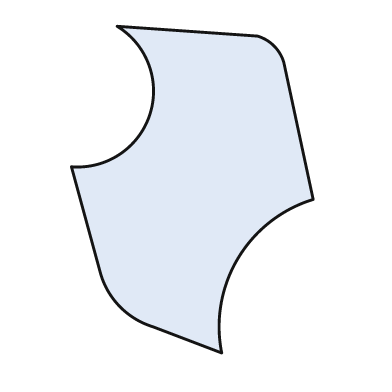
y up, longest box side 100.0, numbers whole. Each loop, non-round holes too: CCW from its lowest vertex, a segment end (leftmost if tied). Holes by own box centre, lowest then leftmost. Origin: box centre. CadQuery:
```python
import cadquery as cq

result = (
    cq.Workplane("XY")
    .moveTo(9.0, -50.0)
    .threePointArc((14.0, -21.0), (37.0, -3.0))
    .lineTo(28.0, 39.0)
    .threePointArc((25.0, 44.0), (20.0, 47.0))
    .lineTo(-23.0, 50.0)
    .threePointArc((-13.0, 23.0), (-37.0, 7.0))
    .lineTo(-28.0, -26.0)
    .threePointArc((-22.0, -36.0), (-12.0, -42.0))
    .close()
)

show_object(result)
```